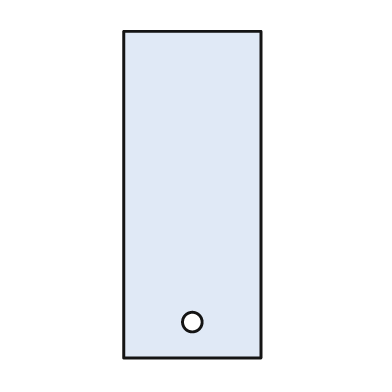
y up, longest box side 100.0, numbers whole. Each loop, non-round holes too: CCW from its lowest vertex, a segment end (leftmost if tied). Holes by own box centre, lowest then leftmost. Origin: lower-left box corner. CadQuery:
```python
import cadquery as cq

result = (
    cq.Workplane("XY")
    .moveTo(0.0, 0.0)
    .lineTo(42.0, 0.0)
    .lineTo(42.0, 100.0)
    .lineTo(0.0, 100.0)
    .close()
    .moveTo(21.0, 11.0)
    .circle(3.0)
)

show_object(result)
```